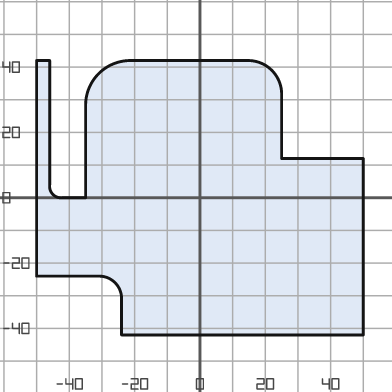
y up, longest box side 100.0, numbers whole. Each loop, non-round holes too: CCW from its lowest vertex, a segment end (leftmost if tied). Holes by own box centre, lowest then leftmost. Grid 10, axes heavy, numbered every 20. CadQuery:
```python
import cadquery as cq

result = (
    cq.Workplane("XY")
    .moveTo(-24.0, -42.0)
    .lineTo(50.0, -42.0)
    .lineTo(50.0, 12.0)
    .lineTo(25.0, 12.0)
    .lineTo(25.0, 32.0)
    .threePointArc((22.0, 39.0), (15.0, 42.0))
    .lineTo(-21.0, 42.0)
    .threePointArc((-31.0, 38.0), (-35.0, 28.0))
    .lineTo(-35.0, 0.0)
    .lineTo(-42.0, 0.0)
    .threePointArc((-45.0, 1.0), (-46.0, 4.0))
    .lineTo(-46.0, 42.0)
    .lineTo(-50.0, 42.0)
    .lineTo(-50.0, -24.0)
    .lineTo(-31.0, -24.0)
    .threePointArc((-26.0, -26.0), (-24.0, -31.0))
    .close()
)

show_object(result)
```